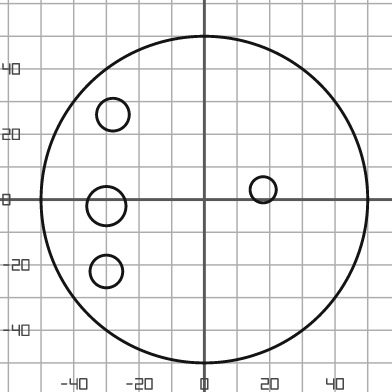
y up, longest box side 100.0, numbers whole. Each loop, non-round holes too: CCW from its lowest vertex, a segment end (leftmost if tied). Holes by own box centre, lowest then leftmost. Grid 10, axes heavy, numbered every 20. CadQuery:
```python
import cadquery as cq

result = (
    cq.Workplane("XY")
    .moveTo(0.0, 0.0)
    .circle(50.0)
    .moveTo(-30.0, -22.0)
    .circle(5.0)
    .moveTo(-30.0, -2.0)
    .circle(6.0)
    .moveTo(18.0, 3.0)
    .circle(4.0)
    .moveTo(-28.0, 26.0)
    .circle(5.0)
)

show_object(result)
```